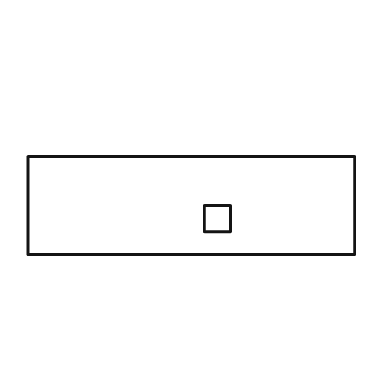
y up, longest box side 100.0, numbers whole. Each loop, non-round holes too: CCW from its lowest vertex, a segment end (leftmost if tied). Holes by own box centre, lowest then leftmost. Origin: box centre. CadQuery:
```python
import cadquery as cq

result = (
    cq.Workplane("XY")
    .moveTo(-50.0, -15.0)
    .lineTo(50.0, -15.0)
    .lineTo(50.0, 15.0)
    .lineTo(-50.0, 15.0)
    .close()
    .moveTo(4.0, -8.0)
    .lineTo(12.0, -8.0)
    .lineTo(12.0, 0.0)
    .lineTo(4.0, 0.0)
    .close()
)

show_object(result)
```